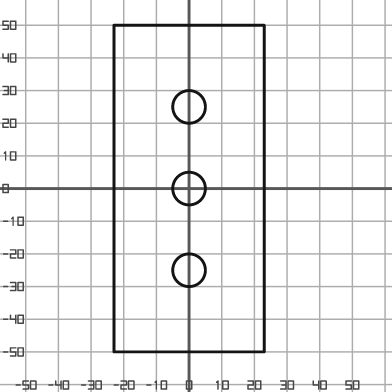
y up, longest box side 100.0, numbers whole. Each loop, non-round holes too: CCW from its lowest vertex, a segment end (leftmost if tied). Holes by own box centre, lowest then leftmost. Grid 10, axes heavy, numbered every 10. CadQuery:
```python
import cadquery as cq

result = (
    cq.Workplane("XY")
    .moveTo(-23.0, -50.0)
    .lineTo(23.0, -50.0)
    .lineTo(23.0, 50.0)
    .lineTo(-23.0, 50.0)
    .close()
    .moveTo(0.0, -25.0)
    .circle(5.0)
    .moveTo(0.0, 0.0)
    .circle(5.0)
    .moveTo(0.0, 25.0)
    .circle(5.0)
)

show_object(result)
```